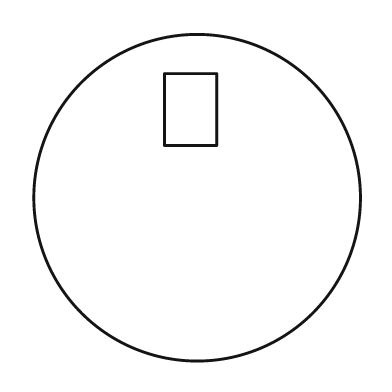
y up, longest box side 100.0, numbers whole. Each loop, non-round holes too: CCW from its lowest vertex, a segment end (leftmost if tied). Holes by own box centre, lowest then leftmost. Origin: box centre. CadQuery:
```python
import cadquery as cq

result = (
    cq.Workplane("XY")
    .moveTo(0.0, 0.0)
    .circle(50.0)
    .moveTo(-10.0, 16.0)
    .lineTo(6.0, 16.0)
    .lineTo(6.0, 38.0)
    .lineTo(-10.0, 38.0)
    .close()
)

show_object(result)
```